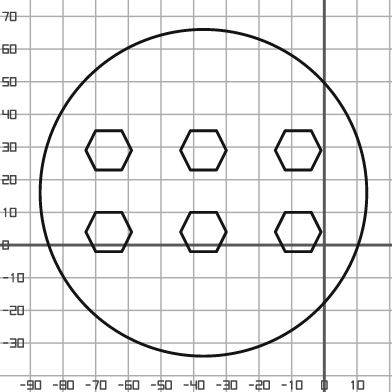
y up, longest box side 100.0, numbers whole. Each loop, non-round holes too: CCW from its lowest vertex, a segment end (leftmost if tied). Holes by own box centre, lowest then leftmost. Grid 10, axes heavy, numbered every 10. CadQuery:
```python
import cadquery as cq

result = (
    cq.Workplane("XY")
    .moveTo(-37.0, 16.0)
    .circle(50.0)
    .moveTo(-70.0, -2.0)
    .lineTo(-62.0, -2.0)
    .lineTo(-59.0, 4.0)
    .lineTo(-62.0, 10.0)
    .lineTo(-70.0, 10.0)
    .lineTo(-73.0, 4.0)
    .close()
    .moveTo(-41.0, -2.0)
    .lineTo(-33.0, -2.0)
    .lineTo(-30.0, 4.0)
    .lineTo(-33.0, 10.0)
    .lineTo(-41.0, 10.0)
    .lineTo(-44.0, 4.0)
    .close()
    .moveTo(-12.0, -2.0)
    .lineTo(-4.0, -2.0)
    .lineTo(-1.0, 4.0)
    .lineTo(-4.0, 10.0)
    .lineTo(-12.0, 10.0)
    .lineTo(-15.0, 4.0)
    .close()
    .moveTo(-70.0, 23.0)
    .lineTo(-62.0, 23.0)
    .lineTo(-59.0, 29.0)
    .lineTo(-62.0, 35.0)
    .lineTo(-70.0, 35.0)
    .lineTo(-73.0, 29.0)
    .close()
    .moveTo(-41.0, 23.0)
    .lineTo(-33.0, 23.0)
    .lineTo(-30.0, 29.0)
    .lineTo(-33.0, 35.0)
    .lineTo(-41.0, 35.0)
    .lineTo(-44.0, 29.0)
    .close()
    .moveTo(-12.0, 23.0)
    .lineTo(-4.0, 23.0)
    .lineTo(-1.0, 29.0)
    .lineTo(-4.0, 35.0)
    .lineTo(-12.0, 35.0)
    .lineTo(-15.0, 29.0)
    .close()
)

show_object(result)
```